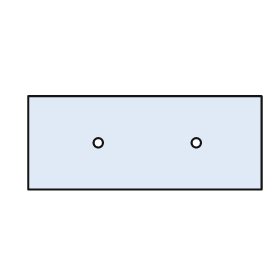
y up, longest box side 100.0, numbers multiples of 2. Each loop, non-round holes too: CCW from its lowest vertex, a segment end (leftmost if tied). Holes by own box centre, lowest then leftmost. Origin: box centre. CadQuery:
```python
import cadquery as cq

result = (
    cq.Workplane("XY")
    .moveTo(-50.0, -20.0)
    .lineTo(50.0, -20.0)
    .lineTo(50.0, 20.0)
    .lineTo(-50.0, 20.0)
    .close()
    .moveTo(-20.0, 0.0)
    .circle(2.0)
    .moveTo(22.0, 0.0)
    .circle(2.0)
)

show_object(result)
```